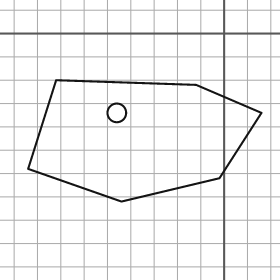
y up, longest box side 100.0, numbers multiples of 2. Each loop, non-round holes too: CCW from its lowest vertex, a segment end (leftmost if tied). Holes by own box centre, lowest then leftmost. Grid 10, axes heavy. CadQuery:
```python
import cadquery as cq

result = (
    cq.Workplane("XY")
    .moveTo(-44.0, -72.0)
    .lineTo(-2.0, -62.0)
    .lineTo(16.0, -34.0)
    .lineTo(-12.0, -22.0)
    .lineTo(-72.0, -20.0)
    .lineTo(-84.0, -58.0)
    .close()
    .moveTo(-46.0, -34.0)
    .circle(4.0)
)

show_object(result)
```